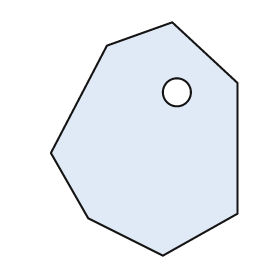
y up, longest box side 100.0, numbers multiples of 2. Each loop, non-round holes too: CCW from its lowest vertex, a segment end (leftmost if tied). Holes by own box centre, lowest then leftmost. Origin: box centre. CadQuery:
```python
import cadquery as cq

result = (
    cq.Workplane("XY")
    .moveTo(8.0, -50.0)
    .lineTo(40.0, -32.0)
    .lineTo(40.0, 24.0)
    .lineTo(12.0, 50.0)
    .lineTo(-16.0, 40.0)
    .lineTo(-40.0, -6.0)
    .lineTo(-24.0, -34.0)
    .close()
    .moveTo(14.0, 20.0)
    .circle(6.0)
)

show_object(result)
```